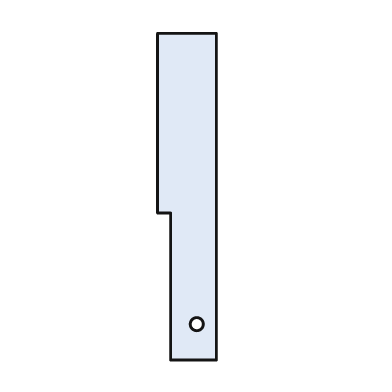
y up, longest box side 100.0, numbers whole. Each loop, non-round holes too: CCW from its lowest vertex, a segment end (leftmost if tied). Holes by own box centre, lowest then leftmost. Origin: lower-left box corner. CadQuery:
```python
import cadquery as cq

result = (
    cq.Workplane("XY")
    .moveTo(4.0, 0.0)
    .lineTo(18.0, 0.0)
    .lineTo(18.0, 100.0)
    .lineTo(0.0, 100.0)
    .lineTo(0.0, 45.0)
    .lineTo(4.0, 45.0)
    .close()
    .moveTo(12.0, 11.0)
    .circle(2.0)
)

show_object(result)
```